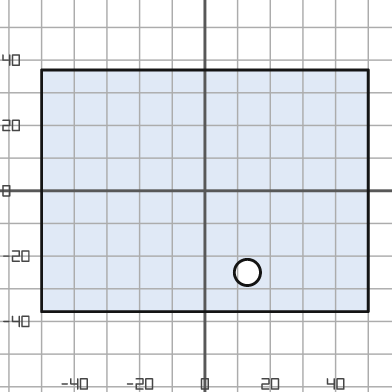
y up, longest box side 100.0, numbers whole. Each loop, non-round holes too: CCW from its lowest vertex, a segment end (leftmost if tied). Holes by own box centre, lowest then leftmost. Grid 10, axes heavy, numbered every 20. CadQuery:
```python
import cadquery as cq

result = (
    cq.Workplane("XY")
    .moveTo(-50.0, -37.0)
    .lineTo(50.0, -37.0)
    .lineTo(50.0, 37.0)
    .lineTo(-50.0, 37.0)
    .close()
    .moveTo(13.0, -25.0)
    .circle(4.0)
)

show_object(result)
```